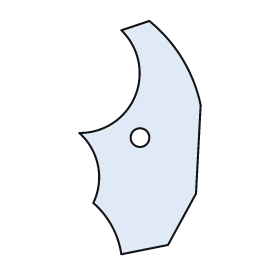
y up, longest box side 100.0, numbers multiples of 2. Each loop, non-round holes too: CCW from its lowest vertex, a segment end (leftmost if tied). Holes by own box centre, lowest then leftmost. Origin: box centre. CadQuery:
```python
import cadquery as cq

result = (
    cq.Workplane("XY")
    .moveTo(-8.0, -50.0)
    .lineTo(12.0, -46.0)
    .lineTo(24.0, -24.0)
    .lineTo(26.0, 14.0)
    .threePointArc((18.0, 34.0), (4.0, 50.0))
    .lineTo(-8.0, 46.0)
    .threePointArc((-2.0, 18.0), (-26.0, 2.0))
    .threePointArc((-18.0, -12.0), (-20.0, -28.0))
    .threePointArc((-12.0, -38.0), (-8.0, -50.0))
    .close()
    .moveTo(0.0, 0.0)
    .circle(4.0)
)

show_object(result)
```